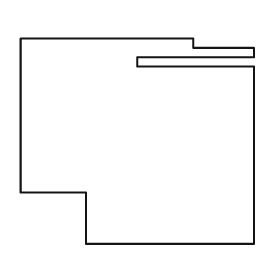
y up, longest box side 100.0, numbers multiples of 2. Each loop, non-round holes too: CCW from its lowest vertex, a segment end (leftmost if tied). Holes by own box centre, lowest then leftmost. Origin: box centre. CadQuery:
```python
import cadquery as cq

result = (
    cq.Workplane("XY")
    .moveTo(-22.0, -44.0)
    .lineTo(50.0, -44.0)
    .lineTo(50.0, 32.0)
    .lineTo(0.0, 32.0)
    .lineTo(0.0, 36.0)
    .lineTo(50.0, 36.0)
    .lineTo(50.0, 40.0)
    .lineTo(24.0, 40.0)
    .lineTo(24.0, 44.0)
    .lineTo(-50.0, 44.0)
    .lineTo(-50.0, -22.0)
    .lineTo(-22.0, -22.0)
    .close()
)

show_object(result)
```